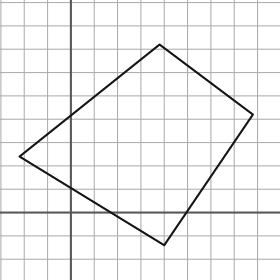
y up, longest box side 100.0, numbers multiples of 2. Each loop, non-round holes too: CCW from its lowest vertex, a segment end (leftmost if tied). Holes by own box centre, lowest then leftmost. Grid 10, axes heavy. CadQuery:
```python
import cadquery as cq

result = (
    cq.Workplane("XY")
    .moveTo(40.0, -14.0)
    .lineTo(78.0, 42.0)
    .lineTo(38.0, 72.0)
    .lineTo(-22.0, 24.0)
    .close()
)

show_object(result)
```